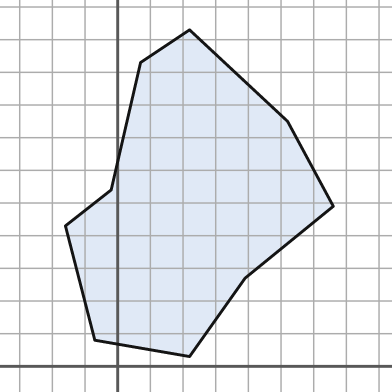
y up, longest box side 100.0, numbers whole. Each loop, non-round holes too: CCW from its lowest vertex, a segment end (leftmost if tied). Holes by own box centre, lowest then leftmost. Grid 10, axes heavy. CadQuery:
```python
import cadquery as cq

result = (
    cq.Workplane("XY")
    .moveTo(22.0, 3.0)
    .lineTo(39.0, 27.0)
    .lineTo(66.0, 49.0)
    .lineTo(52.0, 75.0)
    .lineTo(22.0, 103.0)
    .lineTo(7.0, 93.0)
    .lineTo(-2.0, 54.0)
    .lineTo(-16.0, 43.0)
    .lineTo(-7.0, 8.0)
    .close()
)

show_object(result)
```